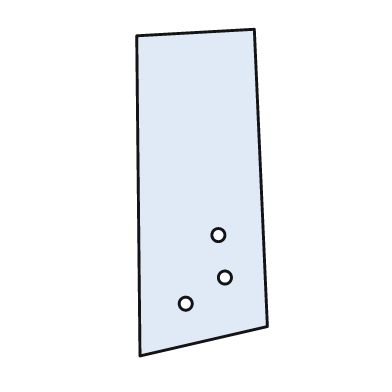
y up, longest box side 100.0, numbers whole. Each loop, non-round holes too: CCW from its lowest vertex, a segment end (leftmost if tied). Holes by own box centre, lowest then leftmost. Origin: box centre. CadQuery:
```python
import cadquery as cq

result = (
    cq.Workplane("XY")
    .moveTo(-19.0, -50.0)
    .lineTo(20.0, -41.0)
    .lineTo(16.0, 50.0)
    .lineTo(-20.0, 48.0)
    .close()
    .moveTo(-5.0, -34.0)
    .circle(2.0)
    .moveTo(7.0, -26.0)
    .circle(2.0)
    .moveTo(5.0, -13.0)
    .circle(2.0)
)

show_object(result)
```